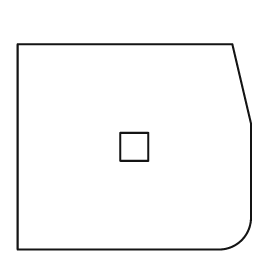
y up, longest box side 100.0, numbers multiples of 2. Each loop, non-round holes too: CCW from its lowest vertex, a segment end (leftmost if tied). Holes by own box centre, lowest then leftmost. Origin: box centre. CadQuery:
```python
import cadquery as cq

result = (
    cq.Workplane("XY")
    .moveTo(-50.0, -44.0)
    .lineTo(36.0, -44.0)
    .threePointArc((46.0, -40.0), (50.0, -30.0))
    .lineTo(50.0, 10.0)
    .lineTo(42.0, 44.0)
    .lineTo(-50.0, 44.0)
    .close()
    .moveTo(-6.0, -6.0)
    .lineTo(6.0, -6.0)
    .lineTo(6.0, 6.0)
    .lineTo(-6.0, 6.0)
    .close()
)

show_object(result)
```